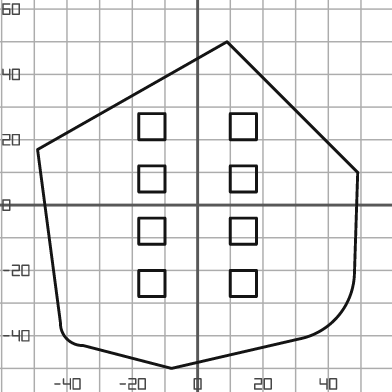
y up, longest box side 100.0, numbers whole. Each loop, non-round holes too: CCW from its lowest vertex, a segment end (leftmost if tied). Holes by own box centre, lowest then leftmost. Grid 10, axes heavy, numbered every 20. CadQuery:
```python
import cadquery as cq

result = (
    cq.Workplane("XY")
    .moveTo(-8.0, -50.0)
    .lineTo(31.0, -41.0)
    .threePointArc((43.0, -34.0), (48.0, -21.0))
    .lineTo(49.0, 10.0)
    .lineTo(9.0, 50.0)
    .lineTo(-49.0, 17.0)
    .lineTo(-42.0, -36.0)
    .threePointArc((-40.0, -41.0), (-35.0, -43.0))
    .close()
    .moveTo(-18.0, -28.0)
    .lineTo(-10.0, -28.0)
    .lineTo(-10.0, -20.0)
    .lineTo(-18.0, -20.0)
    .close()
    .moveTo(10.0, -28.0)
    .lineTo(18.0, -28.0)
    .lineTo(18.0, -20.0)
    .lineTo(10.0, -20.0)
    .close()
    .moveTo(-18.0, -12.0)
    .lineTo(-10.0, -12.0)
    .lineTo(-10.0, -4.0)
    .lineTo(-18.0, -4.0)
    .close()
    .moveTo(10.0, -12.0)
    .lineTo(18.0, -12.0)
    .lineTo(18.0, -4.0)
    .lineTo(10.0, -4.0)
    .close()
    .moveTo(-18.0, 4.0)
    .lineTo(-10.0, 4.0)
    .lineTo(-10.0, 12.0)
    .lineTo(-18.0, 12.0)
    .close()
    .moveTo(10.0, 4.0)
    .lineTo(18.0, 4.0)
    .lineTo(18.0, 12.0)
    .lineTo(10.0, 12.0)
    .close()
    .moveTo(-18.0, 20.0)
    .lineTo(-10.0, 20.0)
    .lineTo(-10.0, 28.0)
    .lineTo(-18.0, 28.0)
    .close()
    .moveTo(10.0, 20.0)
    .lineTo(18.0, 20.0)
    .lineTo(18.0, 28.0)
    .lineTo(10.0, 28.0)
    .close()
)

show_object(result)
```